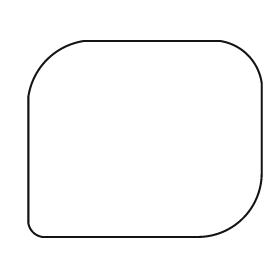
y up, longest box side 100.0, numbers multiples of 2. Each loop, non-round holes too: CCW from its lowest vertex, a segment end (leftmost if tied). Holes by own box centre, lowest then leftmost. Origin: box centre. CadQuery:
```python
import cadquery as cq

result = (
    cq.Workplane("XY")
    .moveTo(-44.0, -42.0)
    .lineTo(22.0, -42.0)
    .threePointArc((42.0, -34.0), (50.0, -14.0))
    .lineTo(50.0, 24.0)
    .threePointArc((44.0, 36.0), (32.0, 42.0))
    .lineTo(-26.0, 42.0)
    .threePointArc((-42.0, 34.0), (-50.0, 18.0))
    .lineTo(-50.0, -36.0)
    .threePointArc((-48.0, -40.0), (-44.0, -42.0))
    .close()
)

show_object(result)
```